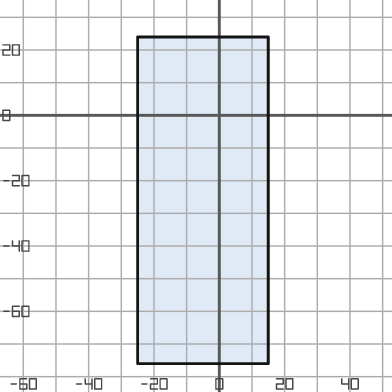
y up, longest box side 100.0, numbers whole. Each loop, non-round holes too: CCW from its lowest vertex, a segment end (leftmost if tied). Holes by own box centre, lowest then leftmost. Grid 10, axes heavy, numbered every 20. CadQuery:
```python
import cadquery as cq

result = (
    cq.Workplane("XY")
    .moveTo(-25.0, -76.0)
    .lineTo(15.0, -76.0)
    .lineTo(15.0, 24.0)
    .lineTo(-25.0, 24.0)
    .close()
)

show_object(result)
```